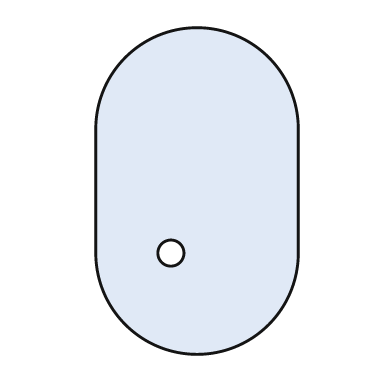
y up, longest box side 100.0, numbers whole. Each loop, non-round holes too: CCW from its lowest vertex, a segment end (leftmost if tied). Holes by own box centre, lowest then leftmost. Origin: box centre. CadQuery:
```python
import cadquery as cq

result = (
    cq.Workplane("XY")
    .moveTo(-31.0, -19.0)
    .threePointArc((0.0, -50.0), (31.0, -19.0))
    .lineTo(31.0, 19.0)
    .threePointArc((0.0, 50.0), (-31.0, 19.0))
    .close()
    .moveTo(-8.0, -19.0)
    .circle(4.0)
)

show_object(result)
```